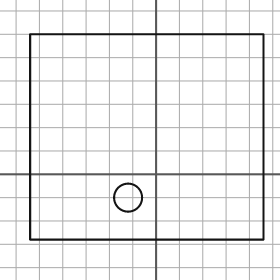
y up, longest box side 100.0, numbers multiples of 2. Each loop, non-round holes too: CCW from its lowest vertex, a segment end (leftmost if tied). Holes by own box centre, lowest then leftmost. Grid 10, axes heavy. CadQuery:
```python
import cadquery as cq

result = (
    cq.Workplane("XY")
    .moveTo(-54.0, -28.0)
    .lineTo(46.0, -28.0)
    .lineTo(46.0, 60.0)
    .lineTo(-54.0, 60.0)
    .close()
    .moveTo(-12.0, -10.0)
    .circle(6.0)
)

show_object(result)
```